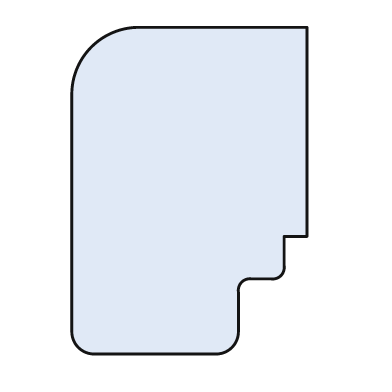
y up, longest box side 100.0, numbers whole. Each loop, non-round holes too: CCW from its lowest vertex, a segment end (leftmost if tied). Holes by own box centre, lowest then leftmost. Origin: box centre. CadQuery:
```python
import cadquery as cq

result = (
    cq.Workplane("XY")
    .moveTo(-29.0, -50.0)
    .lineTo(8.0, -50.0)
    .threePointArc((13.0, -48.0), (15.0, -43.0))
    .lineTo(15.0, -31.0)
    .threePointArc((16.0, -28.0), (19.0, -27.0))
    .lineTo(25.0, -27.0)
    .threePointArc((28.0, -26.0), (29.0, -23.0))
    .lineTo(29.0, -14.0)
    .lineTo(36.0, -14.0)
    .lineTo(36.0, 50.0)
    .lineTo(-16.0, 50.0)
    .threePointArc((-30.0, 44.0), (-36.0, 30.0))
    .lineTo(-36.0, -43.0)
    .threePointArc((-34.0, -48.0), (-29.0, -50.0))
    .close()
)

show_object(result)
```